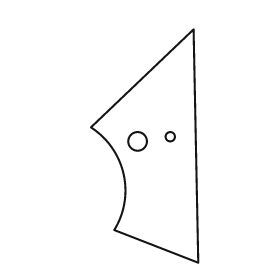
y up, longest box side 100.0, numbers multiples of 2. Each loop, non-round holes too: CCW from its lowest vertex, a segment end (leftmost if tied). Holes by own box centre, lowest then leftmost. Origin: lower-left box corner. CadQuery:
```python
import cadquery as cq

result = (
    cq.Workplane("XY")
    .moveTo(46.0, 0.0)
    .lineTo(44.0, 100.0)
    .lineTo(0.0, 58.0)
    .threePointArc((14.0, 38.0), (10.0, 14.0))
    .close()
    .moveTo(20.0, 52.0)
    .circle(4.0)
    .moveTo(34.0, 54.0)
    .circle(2.0)
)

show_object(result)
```